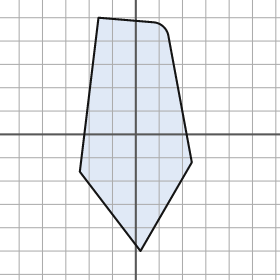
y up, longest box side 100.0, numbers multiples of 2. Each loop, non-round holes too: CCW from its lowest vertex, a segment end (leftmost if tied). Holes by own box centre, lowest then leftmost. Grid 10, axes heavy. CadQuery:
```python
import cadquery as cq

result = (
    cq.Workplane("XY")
    .moveTo(2.0, -50.0)
    .lineTo(24.0, -12.0)
    .lineTo(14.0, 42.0)
    .threePointArc((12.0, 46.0), (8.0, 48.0))
    .lineTo(-16.0, 50.0)
    .lineTo(-24.0, -16.0)
    .close()
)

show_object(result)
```